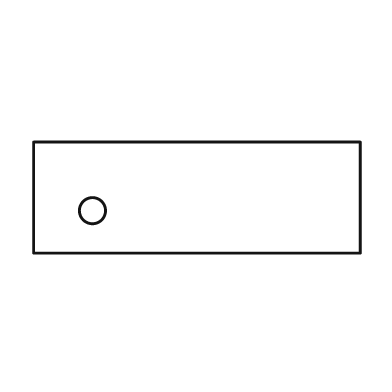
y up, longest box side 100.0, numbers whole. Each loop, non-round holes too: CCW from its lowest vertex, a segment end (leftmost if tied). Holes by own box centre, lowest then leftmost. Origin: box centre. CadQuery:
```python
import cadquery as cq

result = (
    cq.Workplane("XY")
    .moveTo(-50.0, -17.0)
    .lineTo(50.0, -17.0)
    .lineTo(50.0, 17.0)
    .lineTo(-50.0, 17.0)
    .close()
    .moveTo(-32.0, -4.0)
    .circle(4.0)
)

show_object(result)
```